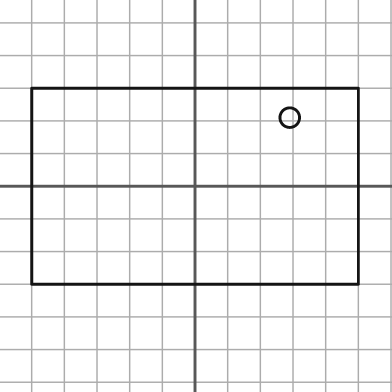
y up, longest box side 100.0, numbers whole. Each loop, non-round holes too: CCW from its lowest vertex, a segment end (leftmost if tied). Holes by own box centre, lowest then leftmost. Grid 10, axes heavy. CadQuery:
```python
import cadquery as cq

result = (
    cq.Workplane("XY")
    .moveTo(-50.0, -30.0)
    .lineTo(50.0, -30.0)
    .lineTo(50.0, 30.0)
    .lineTo(-50.0, 30.0)
    .close()
    .moveTo(29.0, 21.0)
    .circle(3.0)
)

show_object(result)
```